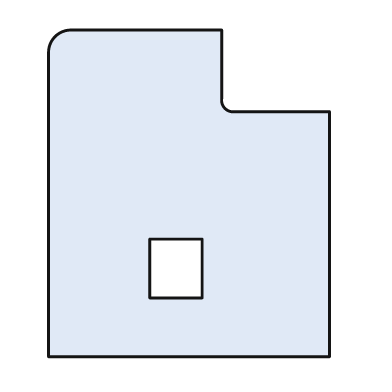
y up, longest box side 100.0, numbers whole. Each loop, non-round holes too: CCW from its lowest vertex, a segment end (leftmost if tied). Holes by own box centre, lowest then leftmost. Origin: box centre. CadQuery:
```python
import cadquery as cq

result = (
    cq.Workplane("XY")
    .moveTo(-43.0, -50.0)
    .lineTo(43.0, -50.0)
    .lineTo(43.0, 25.0)
    .lineTo(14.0, 25.0)
    .threePointArc((11.0, 26.0), (10.0, 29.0))
    .lineTo(10.0, 50.0)
    .lineTo(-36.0, 50.0)
    .threePointArc((-41.0, 48.0), (-43.0, 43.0))
    .close()
    .moveTo(-12.0, -32.0)
    .lineTo(4.0, -32.0)
    .lineTo(4.0, -14.0)
    .lineTo(-12.0, -14.0)
    .close()
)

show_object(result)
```